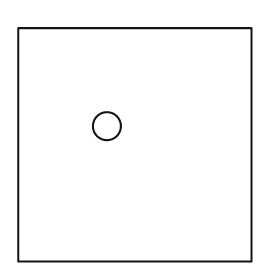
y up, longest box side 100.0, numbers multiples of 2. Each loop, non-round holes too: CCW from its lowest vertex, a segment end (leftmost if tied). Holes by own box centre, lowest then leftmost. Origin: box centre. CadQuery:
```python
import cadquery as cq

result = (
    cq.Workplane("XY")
    .moveTo(-50.0, -50.0)
    .lineTo(50.0, -50.0)
    .lineTo(50.0, 50.0)
    .lineTo(-50.0, 50.0)
    .close()
    .moveTo(-12.0, 8.0)
    .circle(6.0)
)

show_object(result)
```